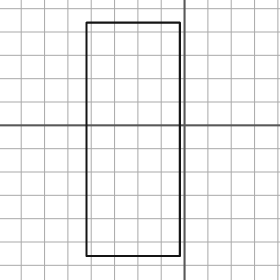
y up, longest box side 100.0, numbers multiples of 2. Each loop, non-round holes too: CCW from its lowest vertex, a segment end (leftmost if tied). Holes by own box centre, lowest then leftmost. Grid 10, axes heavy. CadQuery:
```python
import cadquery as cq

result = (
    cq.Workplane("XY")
    .moveTo(-42.0, -56.0)
    .lineTo(-2.0, -56.0)
    .lineTo(-2.0, 44.0)
    .lineTo(-42.0, 44.0)
    .close()
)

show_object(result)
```